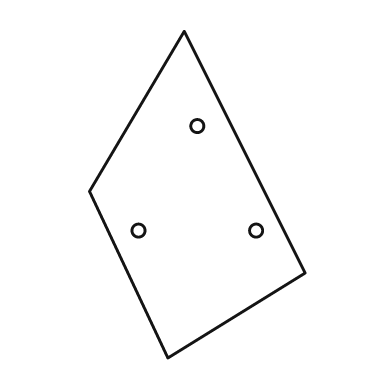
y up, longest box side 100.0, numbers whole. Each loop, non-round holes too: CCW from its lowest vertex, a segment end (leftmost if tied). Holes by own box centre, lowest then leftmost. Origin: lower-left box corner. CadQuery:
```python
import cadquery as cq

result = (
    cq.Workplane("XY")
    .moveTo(24.0, 0.0)
    .lineTo(66.0, 26.0)
    .lineTo(29.0, 100.0)
    .lineTo(0.0, 51.0)
    .close()
    .moveTo(15.0, 39.0)
    .circle(2.0)
    .moveTo(51.0, 39.0)
    .circle(2.0)
    .moveTo(33.0, 71.0)
    .circle(2.0)
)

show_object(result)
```